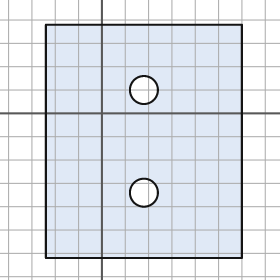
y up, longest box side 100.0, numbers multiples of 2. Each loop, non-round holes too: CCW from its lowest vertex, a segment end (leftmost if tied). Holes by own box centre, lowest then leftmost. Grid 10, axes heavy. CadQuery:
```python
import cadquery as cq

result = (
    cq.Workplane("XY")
    .moveTo(-24.0, -62.0)
    .lineTo(60.0, -62.0)
    .lineTo(60.0, 38.0)
    .lineTo(-24.0, 38.0)
    .close()
    .moveTo(18.0, -34.0)
    .circle(6.0)
    .moveTo(18.0, 10.0)
    .circle(6.0)
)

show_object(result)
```